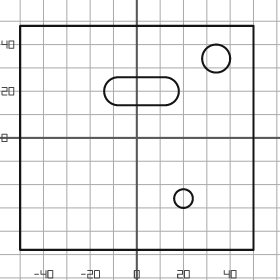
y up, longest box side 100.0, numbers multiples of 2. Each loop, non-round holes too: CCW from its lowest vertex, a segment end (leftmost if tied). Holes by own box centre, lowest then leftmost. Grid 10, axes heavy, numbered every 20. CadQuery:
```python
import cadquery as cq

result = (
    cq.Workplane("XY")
    .moveTo(-50.0, -48.0)
    .lineTo(50.0, -48.0)
    .lineTo(50.0, 48.0)
    .lineTo(-50.0, 48.0)
    .close()
    .moveTo(20.0, -26.0)
    .circle(4.0)
    .moveTo(-8.0, 14.0)
    .lineTo(12.0, 14.0)
    .threePointArc((18.0, 20.0), (12.0, 26.0))
    .lineTo(-8.0, 26.0)
    .threePointArc((-14.0, 20.0), (-8.0, 14.0))
    .close()
    .moveTo(34.0, 34.0)
    .circle(6.0)
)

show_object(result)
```